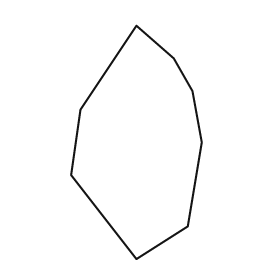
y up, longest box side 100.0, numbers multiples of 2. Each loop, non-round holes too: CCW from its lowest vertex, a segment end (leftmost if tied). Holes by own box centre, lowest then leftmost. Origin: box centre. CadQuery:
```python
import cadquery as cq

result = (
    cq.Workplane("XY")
    .moveTo(0.0, -50.0)
    .lineTo(22.0, -36.0)
    .lineTo(28.0, 0.0)
    .lineTo(24.0, 22.0)
    .lineTo(16.0, 36.0)
    .lineTo(0.0, 50.0)
    .lineTo(-24.0, 14.0)
    .lineTo(-28.0, -14.0)
    .close()
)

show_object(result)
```